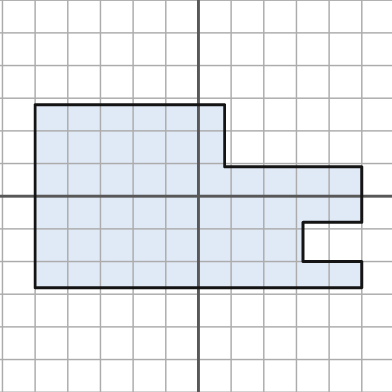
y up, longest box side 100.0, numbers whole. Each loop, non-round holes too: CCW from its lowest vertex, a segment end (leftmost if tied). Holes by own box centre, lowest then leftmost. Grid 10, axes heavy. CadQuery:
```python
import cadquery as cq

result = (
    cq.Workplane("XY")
    .moveTo(-50.0, -28.0)
    .lineTo(50.0, -28.0)
    .lineTo(50.0, -20.0)
    .lineTo(32.0, -20.0)
    .lineTo(32.0, -8.0)
    .lineTo(50.0, -8.0)
    .lineTo(50.0, 9.0)
    .lineTo(8.0, 9.0)
    .lineTo(8.0, 28.0)
    .lineTo(-50.0, 28.0)
    .close()
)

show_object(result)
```